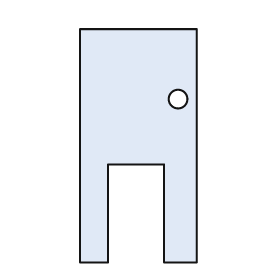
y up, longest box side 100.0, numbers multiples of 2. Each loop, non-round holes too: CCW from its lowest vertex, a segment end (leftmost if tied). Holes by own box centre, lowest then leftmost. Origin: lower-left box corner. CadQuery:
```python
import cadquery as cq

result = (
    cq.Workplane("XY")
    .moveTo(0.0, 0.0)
    .lineTo(12.0, 0.0)
    .lineTo(12.0, 42.0)
    .lineTo(36.0, 42.0)
    .lineTo(36.0, 0.0)
    .lineTo(50.0, 0.0)
    .lineTo(50.0, 100.0)
    .lineTo(0.0, 100.0)
    .close()
    .moveTo(42.0, 70.0)
    .circle(4.0)
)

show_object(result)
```